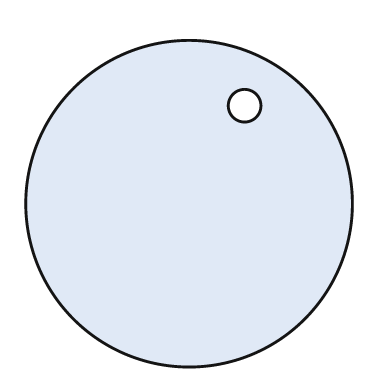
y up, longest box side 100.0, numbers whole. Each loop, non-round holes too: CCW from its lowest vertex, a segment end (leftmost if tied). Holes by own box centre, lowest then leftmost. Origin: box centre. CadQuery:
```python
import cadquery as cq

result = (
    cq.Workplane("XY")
    .moveTo(0.0, 0.0)
    .circle(50.0)
    .moveTo(17.0, 30.0)
    .circle(5.0)
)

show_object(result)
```